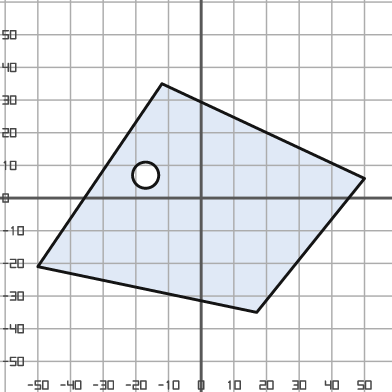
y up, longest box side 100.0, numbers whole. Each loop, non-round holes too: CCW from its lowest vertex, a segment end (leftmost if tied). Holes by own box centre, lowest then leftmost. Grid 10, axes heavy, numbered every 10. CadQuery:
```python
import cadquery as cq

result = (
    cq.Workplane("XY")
    .moveTo(17.0, -35.0)
    .lineTo(50.0, 6.0)
    .lineTo(-12.0, 35.0)
    .lineTo(-50.0, -21.0)
    .close()
    .moveTo(-17.0, 7.0)
    .circle(4.0)
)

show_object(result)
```